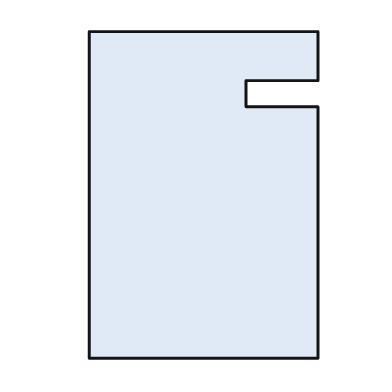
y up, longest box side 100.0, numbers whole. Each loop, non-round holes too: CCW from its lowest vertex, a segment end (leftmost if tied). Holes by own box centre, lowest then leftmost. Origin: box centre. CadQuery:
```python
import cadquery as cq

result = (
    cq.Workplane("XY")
    .moveTo(-35.0, -50.0)
    .lineTo(35.0, -50.0)
    .lineTo(35.0, 27.0)
    .lineTo(13.0, 27.0)
    .lineTo(13.0, 35.0)
    .lineTo(35.0, 35.0)
    .lineTo(35.0, 50.0)
    .lineTo(-35.0, 50.0)
    .close()
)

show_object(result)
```